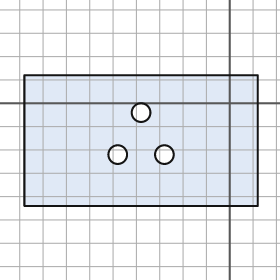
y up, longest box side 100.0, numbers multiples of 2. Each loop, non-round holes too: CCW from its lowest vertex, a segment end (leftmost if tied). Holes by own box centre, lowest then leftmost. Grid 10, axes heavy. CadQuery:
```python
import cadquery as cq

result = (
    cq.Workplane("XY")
    .moveTo(-88.0, -44.0)
    .lineTo(12.0, -44.0)
    .lineTo(12.0, 12.0)
    .lineTo(-88.0, 12.0)
    .close()
    .moveTo(-48.0, -22.0)
    .circle(4.0)
    .moveTo(-28.0, -22.0)
    .circle(4.0)
    .moveTo(-38.0, -4.0)
    .circle(4.0)
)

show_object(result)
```